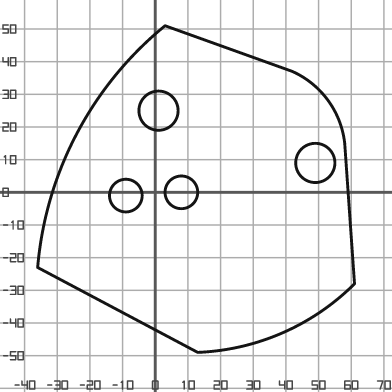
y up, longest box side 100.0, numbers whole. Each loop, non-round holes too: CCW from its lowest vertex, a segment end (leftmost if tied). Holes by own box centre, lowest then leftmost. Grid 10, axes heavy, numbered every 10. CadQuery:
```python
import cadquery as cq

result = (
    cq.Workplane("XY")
    .moveTo(13.0, -49.0)
    .threePointArc((39.0, -43.0), (61.0, -28.0))
    .lineTo(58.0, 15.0)
    .threePointArc((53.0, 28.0), (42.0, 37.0))
    .lineTo(3.0, 51.0)
    .threePointArc((-24.0, 18.0), (-36.0, -23.0))
    .close()
    .moveTo(-9.0, -1.0)
    .circle(5.0)
    .moveTo(8.0, 0.0)
    .circle(5.0)
    .moveTo(49.0, 9.0)
    .circle(6.0)
    .moveTo(1.0, 25.0)
    .circle(6.0)
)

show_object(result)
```